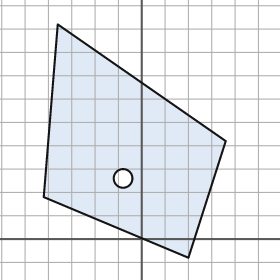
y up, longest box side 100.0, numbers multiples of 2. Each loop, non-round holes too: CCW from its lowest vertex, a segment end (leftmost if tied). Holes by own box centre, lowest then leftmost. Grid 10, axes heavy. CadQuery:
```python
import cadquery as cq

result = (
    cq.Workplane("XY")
    .moveTo(20.0, -8.0)
    .lineTo(36.0, 42.0)
    .lineTo(-36.0, 92.0)
    .lineTo(-42.0, 18.0)
    .close()
    .moveTo(-8.0, 26.0)
    .circle(4.0)
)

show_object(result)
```